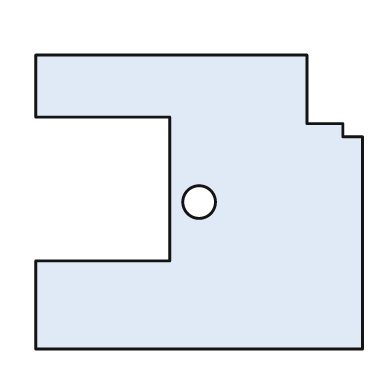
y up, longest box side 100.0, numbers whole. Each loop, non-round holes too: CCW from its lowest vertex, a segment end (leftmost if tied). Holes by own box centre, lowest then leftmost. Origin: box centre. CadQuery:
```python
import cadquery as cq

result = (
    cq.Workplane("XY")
    .moveTo(-50.0, -45.0)
    .lineTo(50.0, -45.0)
    .lineTo(50.0, 20.0)
    .lineTo(44.0, 20.0)
    .lineTo(44.0, 24.0)
    .lineTo(33.0, 24.0)
    .lineTo(33.0, 45.0)
    .lineTo(-50.0, 45.0)
    .lineTo(-50.0, 26.0)
    .lineTo(-9.0, 26.0)
    .lineTo(-9.0, -18.0)
    .lineTo(-50.0, -18.0)
    .close()
    .moveTo(0.0, 0.0)
    .circle(5.0)
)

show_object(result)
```